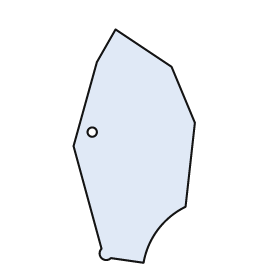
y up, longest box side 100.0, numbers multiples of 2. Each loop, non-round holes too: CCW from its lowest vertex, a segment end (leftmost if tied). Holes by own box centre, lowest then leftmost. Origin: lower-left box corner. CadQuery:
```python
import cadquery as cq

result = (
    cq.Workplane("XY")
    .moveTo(30.0, 0.0)
    .threePointArc((36.0, 14.0), (48.0, 24.0))
    .lineTo(52.0, 60.0)
    .lineTo(42.0, 84.0)
    .lineTo(18.0, 100.0)
    .lineTo(10.0, 86.0)
    .lineTo(0.0, 50.0)
    .lineTo(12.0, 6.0)
    .threePointArc((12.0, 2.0), (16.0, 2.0))
    .close()
    .moveTo(8.0, 56.0)
    .circle(2.0)
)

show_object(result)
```